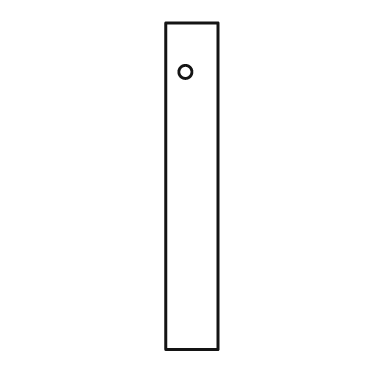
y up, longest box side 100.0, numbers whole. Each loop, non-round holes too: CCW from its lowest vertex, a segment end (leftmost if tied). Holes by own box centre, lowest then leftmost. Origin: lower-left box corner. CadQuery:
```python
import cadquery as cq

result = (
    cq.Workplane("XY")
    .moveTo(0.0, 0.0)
    .lineTo(16.0, 0.0)
    .lineTo(16.0, 100.0)
    .lineTo(0.0, 100.0)
    .close()
    .moveTo(6.0, 85.0)
    .circle(2.0)
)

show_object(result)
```